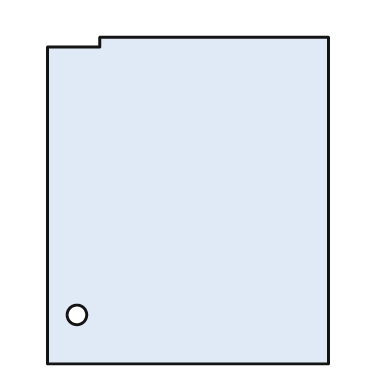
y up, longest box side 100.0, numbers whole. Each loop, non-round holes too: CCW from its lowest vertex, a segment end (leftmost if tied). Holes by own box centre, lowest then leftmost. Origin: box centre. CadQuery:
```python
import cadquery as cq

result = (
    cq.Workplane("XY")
    .moveTo(-43.0, -50.0)
    .lineTo(43.0, -50.0)
    .lineTo(43.0, 50.0)
    .lineTo(-27.0, 50.0)
    .lineTo(-27.0, 47.0)
    .lineTo(-43.0, 47.0)
    .close()
    .moveTo(-34.0, -35.0)
    .circle(3.0)
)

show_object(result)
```